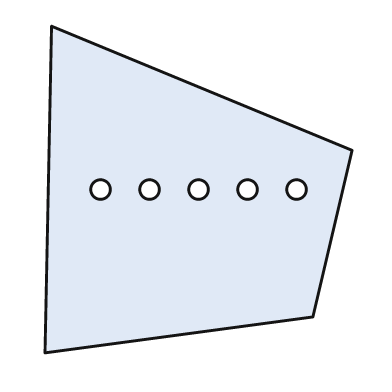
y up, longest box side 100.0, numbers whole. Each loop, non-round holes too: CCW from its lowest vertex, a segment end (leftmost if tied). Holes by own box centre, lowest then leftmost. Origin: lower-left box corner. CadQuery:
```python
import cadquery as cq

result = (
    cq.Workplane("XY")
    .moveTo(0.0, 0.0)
    .lineTo(82.0, 11.0)
    .lineTo(94.0, 62.0)
    .lineTo(2.0, 100.0)
    .close()
    .moveTo(17.0, 50.0)
    .circle(3.0)
    .moveTo(32.0, 50.0)
    .circle(3.0)
    .moveTo(47.0, 50.0)
    .circle(3.0)
    .moveTo(62.0, 50.0)
    .circle(3.0)
    .moveTo(77.0, 50.0)
    .circle(3.0)
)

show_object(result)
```